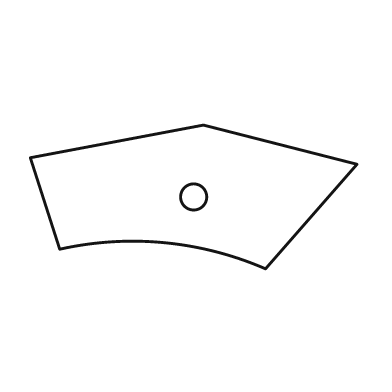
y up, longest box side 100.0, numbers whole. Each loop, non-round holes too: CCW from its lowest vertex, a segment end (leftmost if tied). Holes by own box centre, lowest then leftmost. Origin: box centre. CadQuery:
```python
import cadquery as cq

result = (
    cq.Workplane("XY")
    .moveTo(22.0, -22.0)
    .lineTo(50.0, 10.0)
    .lineTo(3.0, 22.0)
    .lineTo(-50.0, 12.0)
    .lineTo(-41.0, -16.0)
    .threePointArc((-9.0, -14.0), (22.0, -22.0))
    .close()
    .moveTo(0.0, 0.0)
    .circle(4.0)
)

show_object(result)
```